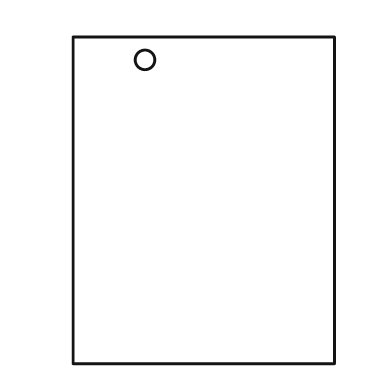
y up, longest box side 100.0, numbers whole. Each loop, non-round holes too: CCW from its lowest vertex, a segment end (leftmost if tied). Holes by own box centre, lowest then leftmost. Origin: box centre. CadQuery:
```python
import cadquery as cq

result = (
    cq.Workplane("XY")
    .moveTo(-40.0, -50.0)
    .lineTo(40.0, -50.0)
    .lineTo(40.0, 50.0)
    .lineTo(-40.0, 50.0)
    .close()
    .moveTo(-18.0, 43.0)
    .circle(3.0)
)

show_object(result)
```